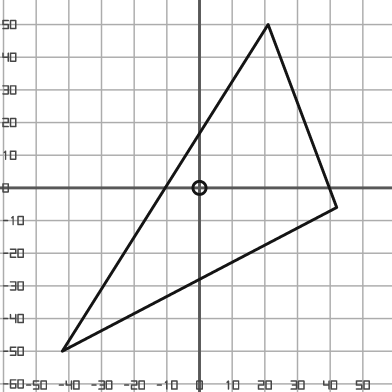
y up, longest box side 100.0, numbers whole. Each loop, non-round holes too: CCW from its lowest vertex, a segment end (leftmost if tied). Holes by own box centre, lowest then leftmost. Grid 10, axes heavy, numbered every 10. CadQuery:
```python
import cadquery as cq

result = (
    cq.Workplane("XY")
    .moveTo(-42.0, -50.0)
    .lineTo(42.0, -6.0)
    .lineTo(21.0, 50.0)
    .close()
    .moveTo(0.0, 0.0)
    .circle(2.0)
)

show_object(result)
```